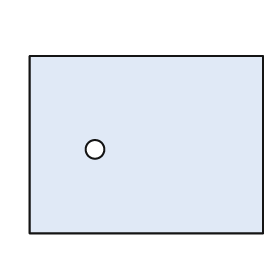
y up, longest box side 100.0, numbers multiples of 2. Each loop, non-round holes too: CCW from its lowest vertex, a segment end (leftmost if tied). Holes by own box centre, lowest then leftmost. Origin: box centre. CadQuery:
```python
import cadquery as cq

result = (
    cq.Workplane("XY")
    .moveTo(-50.0, -38.0)
    .lineTo(50.0, -38.0)
    .lineTo(50.0, 38.0)
    .lineTo(-50.0, 38.0)
    .close()
    .moveTo(-22.0, -2.0)
    .circle(4.0)
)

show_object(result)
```